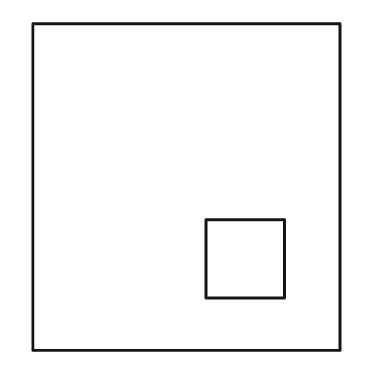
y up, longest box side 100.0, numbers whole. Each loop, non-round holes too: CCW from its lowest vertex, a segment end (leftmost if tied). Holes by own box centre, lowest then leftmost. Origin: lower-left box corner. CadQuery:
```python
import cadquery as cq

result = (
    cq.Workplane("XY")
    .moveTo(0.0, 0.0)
    .lineTo(94.0, 0.0)
    .lineTo(94.0, 100.0)
    .lineTo(0.0, 100.0)
    .close()
    .moveTo(53.0, 16.0)
    .lineTo(77.0, 16.0)
    .lineTo(77.0, 40.0)
    .lineTo(53.0, 40.0)
    .close()
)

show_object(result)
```